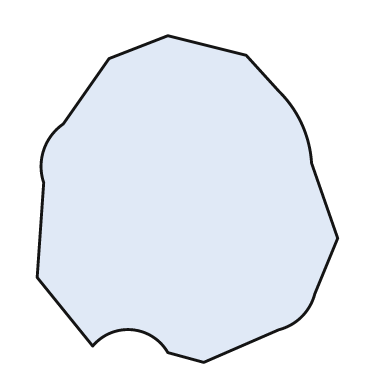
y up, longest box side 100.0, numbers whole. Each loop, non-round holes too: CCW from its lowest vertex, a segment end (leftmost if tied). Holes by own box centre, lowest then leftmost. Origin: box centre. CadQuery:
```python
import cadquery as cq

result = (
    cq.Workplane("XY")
    .moveTo(5.0, -50.0)
    .lineTo(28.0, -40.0)
    .threePointArc((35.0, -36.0), (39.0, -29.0))
    .lineTo(46.0, -12.0)
    .lineTo(38.0, 11.0)
    .threePointArc((35.0, 23.0), (28.0, 33.0))
    .lineTo(18.0, 44.0)
    .lineTo(-6.0, 50.0)
    .lineTo(-24.0, 43.0)
    .lineTo(-38.0, 23.0)
    .threePointArc((-44.0, 15.0), (-44.0, 5.0))
    .lineTo(-46.0, -24.0)
    .lineTo(-29.0, -45.0)
    .threePointArc((-17.0, -40.0), (-6.0, -47.0))
    .close()
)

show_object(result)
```